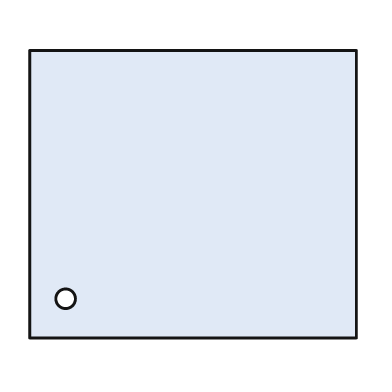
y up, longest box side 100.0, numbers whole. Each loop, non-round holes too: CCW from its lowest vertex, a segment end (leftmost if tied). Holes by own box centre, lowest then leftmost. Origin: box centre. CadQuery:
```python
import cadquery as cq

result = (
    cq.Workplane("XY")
    .moveTo(-50.0, -44.0)
    .lineTo(50.0, -44.0)
    .lineTo(50.0, 44.0)
    .lineTo(-50.0, 44.0)
    .close()
    .moveTo(-39.0, -32.0)
    .circle(3.0)
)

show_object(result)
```